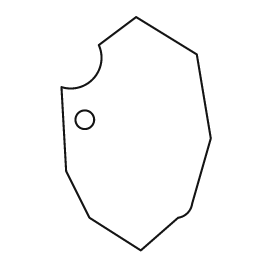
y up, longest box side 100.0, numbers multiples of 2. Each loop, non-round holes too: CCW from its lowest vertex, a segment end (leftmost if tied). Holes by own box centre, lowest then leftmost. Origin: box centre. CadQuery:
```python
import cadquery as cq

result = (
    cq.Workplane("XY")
    .moveTo(2.0, -50.0)
    .lineTo(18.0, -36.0)
    .threePointArc((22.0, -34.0), (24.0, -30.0))
    .lineTo(32.0, -2.0)
    .lineTo(26.0, 34.0)
    .lineTo(0.0, 50.0)
    .lineTo(-16.0, 38.0)
    .threePointArc((-18.0, 24.0), (-32.0, 20.0))
    .lineTo(-30.0, -16.0)
    .lineTo(-20.0, -36.0)
    .close()
    .moveTo(-22.0, 6.0)
    .circle(4.0)
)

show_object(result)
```